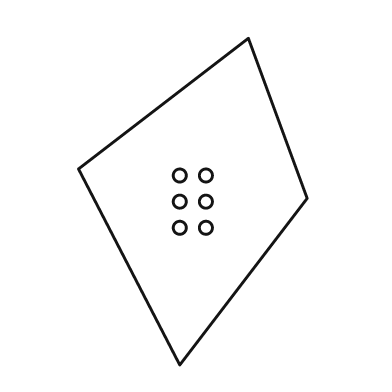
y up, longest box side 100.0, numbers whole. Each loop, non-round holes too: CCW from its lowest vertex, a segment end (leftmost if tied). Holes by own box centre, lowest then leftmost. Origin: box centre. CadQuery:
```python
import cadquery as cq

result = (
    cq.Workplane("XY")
    .moveTo(-4.0, -50.0)
    .lineTo(35.0, 1.0)
    .lineTo(17.0, 50.0)
    .lineTo(-35.0, 10.0)
    .close()
    .moveTo(-4.0, -8.0)
    .circle(2.0)
    .moveTo(4.0, -8.0)
    .circle(2.0)
    .moveTo(-4.0, 0.0)
    .circle(2.0)
    .moveTo(4.0, 0.0)
    .circle(2.0)
    .moveTo(-4.0, 8.0)
    .circle(2.0)
    .moveTo(4.0, 8.0)
    .circle(2.0)
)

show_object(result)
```